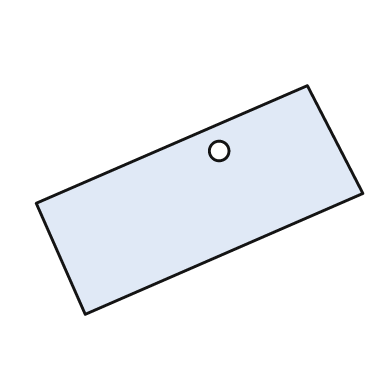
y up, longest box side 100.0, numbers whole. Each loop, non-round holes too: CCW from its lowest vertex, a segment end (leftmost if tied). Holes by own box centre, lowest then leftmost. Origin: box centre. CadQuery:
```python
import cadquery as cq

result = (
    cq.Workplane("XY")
    .moveTo(-35.0, -35.0)
    .lineTo(50.0, 2.0)
    .lineTo(33.0, 35.0)
    .lineTo(-50.0, -1.0)
    .close()
    .moveTo(6.0, 15.0)
    .circle(3.0)
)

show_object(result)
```